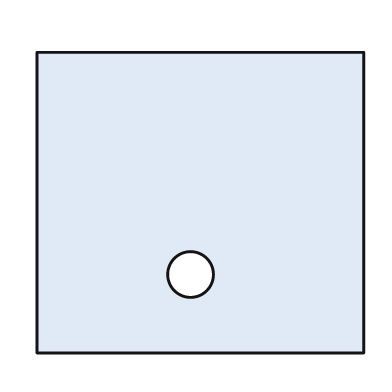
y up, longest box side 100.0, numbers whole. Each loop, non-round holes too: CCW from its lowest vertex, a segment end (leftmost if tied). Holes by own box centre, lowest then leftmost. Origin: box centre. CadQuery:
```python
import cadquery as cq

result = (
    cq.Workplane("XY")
    .moveTo(-50.0, -46.0)
    .lineTo(50.0, -46.0)
    .lineTo(50.0, 46.0)
    .lineTo(-50.0, 46.0)
    .close()
    .moveTo(-3.0, -22.0)
    .circle(7.0)
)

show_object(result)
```